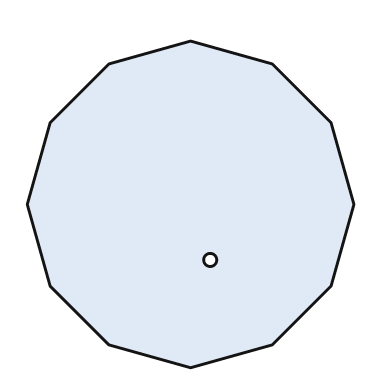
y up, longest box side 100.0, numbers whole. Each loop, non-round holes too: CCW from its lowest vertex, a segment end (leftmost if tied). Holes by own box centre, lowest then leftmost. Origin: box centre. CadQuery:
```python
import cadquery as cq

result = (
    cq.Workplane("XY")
    .moveTo(0.0, -50.0)
    .lineTo(25.0, -43.0)
    .lineTo(43.0, -25.0)
    .lineTo(50.0, 0.0)
    .lineTo(43.0, 25.0)
    .lineTo(25.0, 43.0)
    .lineTo(0.0, 50.0)
    .lineTo(-25.0, 43.0)
    .lineTo(-43.0, 25.0)
    .lineTo(-50.0, 0.0)
    .lineTo(-43.0, -25.0)
    .lineTo(-25.0, -43.0)
    .close()
    .moveTo(6.0, -17.0)
    .circle(2.0)
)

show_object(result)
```